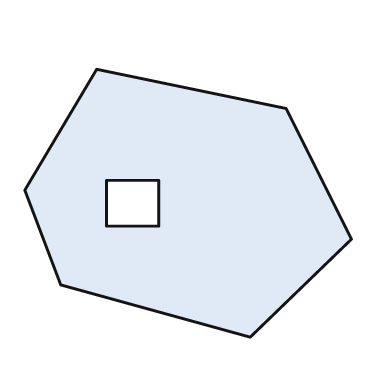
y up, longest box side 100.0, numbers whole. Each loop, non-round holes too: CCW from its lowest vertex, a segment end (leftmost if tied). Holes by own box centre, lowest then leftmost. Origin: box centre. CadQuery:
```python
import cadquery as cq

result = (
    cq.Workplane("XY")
    .moveTo(19.0, -41.0)
    .lineTo(50.0, -11.0)
    .lineTo(30.0, 29.0)
    .lineTo(-28.0, 41.0)
    .lineTo(-50.0, 4.0)
    .lineTo(-39.0, -25.0)
    .close()
    .moveTo(-25.0, -7.0)
    .lineTo(-9.0, -7.0)
    .lineTo(-9.0, 7.0)
    .lineTo(-25.0, 7.0)
    .close()
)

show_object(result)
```